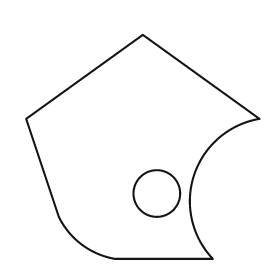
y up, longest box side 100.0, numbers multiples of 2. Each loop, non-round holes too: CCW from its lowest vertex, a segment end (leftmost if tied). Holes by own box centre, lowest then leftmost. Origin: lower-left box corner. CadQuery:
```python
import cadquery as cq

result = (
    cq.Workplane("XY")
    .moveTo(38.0, 0.0)
    .lineTo(80.0, 0.0)
    .threePointArc((72.0, 36.0), (100.0, 60.0))
    .lineTo(50.0, 96.0)
    .lineTo(0.0, 60.0)
    .lineTo(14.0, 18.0)
    .threePointArc((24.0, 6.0), (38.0, 0.0))
    .close()
    .moveTo(56.0, 28.0)
    .circle(10.0)
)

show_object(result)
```